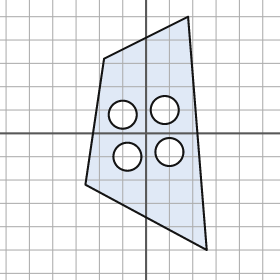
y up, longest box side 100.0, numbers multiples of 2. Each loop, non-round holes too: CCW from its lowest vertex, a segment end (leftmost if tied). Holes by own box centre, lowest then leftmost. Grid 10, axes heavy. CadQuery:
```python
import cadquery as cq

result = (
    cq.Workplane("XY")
    .moveTo(26.0, -50.0)
    .lineTo(18.0, 50.0)
    .lineTo(-18.0, 32.0)
    .lineTo(-26.0, -22.0)
    .close()
    .moveTo(-8.0, -10.0)
    .circle(6.0)
    .moveTo(10.0, -8.0)
    .circle(6.0)
    .moveTo(-10.0, 8.0)
    .circle(6.0)
    .moveTo(8.0, 10.0)
    .circle(6.0)
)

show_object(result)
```